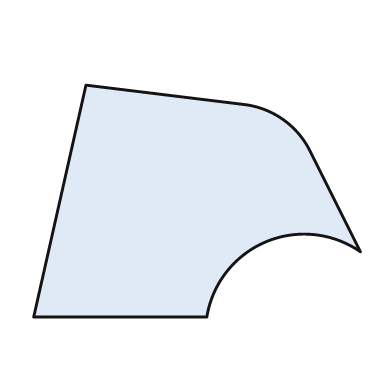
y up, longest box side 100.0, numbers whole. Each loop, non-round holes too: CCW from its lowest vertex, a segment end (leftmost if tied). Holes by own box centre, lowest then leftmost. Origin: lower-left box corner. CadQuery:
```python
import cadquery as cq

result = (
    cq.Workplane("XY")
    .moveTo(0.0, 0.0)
    .lineTo(53.0, 0.0)
    .threePointArc((71.0, 23.0), (100.0, 20.0))
    .lineTo(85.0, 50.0)
    .threePointArc((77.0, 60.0), (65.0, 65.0))
    .lineTo(16.0, 71.0)
    .close()
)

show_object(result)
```